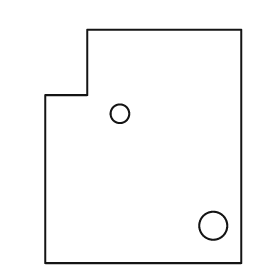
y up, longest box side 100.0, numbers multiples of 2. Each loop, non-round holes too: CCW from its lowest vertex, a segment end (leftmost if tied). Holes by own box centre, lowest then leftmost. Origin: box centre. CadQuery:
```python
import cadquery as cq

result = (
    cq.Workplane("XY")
    .moveTo(-42.0, -50.0)
    .lineTo(42.0, -50.0)
    .lineTo(42.0, 50.0)
    .lineTo(-24.0, 50.0)
    .lineTo(-24.0, 22.0)
    .lineTo(-42.0, 22.0)
    .close()
    .moveTo(30.0, -34.0)
    .circle(6.0)
    .moveTo(-10.0, 14.0)
    .circle(4.0)
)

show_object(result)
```